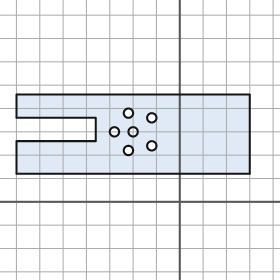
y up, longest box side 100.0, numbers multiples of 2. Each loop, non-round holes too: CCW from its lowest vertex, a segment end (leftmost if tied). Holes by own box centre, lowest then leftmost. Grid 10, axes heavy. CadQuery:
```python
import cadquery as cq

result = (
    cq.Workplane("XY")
    .moveTo(-70.0, 12.0)
    .lineTo(30.0, 12.0)
    .lineTo(30.0, 46.0)
    .lineTo(-70.0, 46.0)
    .lineTo(-70.0, 36.0)
    .lineTo(-36.0, 36.0)
    .lineTo(-36.0, 26.0)
    .lineTo(-70.0, 26.0)
    .close()
    .moveTo(-22.0, 22.0)
    .circle(2.0)
    .moveTo(-12.0, 24.0)
    .circle(2.0)
    .moveTo(-28.0, 30.0)
    .circle(2.0)
    .moveTo(-20.0, 30.0)
    .circle(2.0)
    .moveTo(-12.0, 36.0)
    .circle(2.0)
    .moveTo(-22.0, 38.0)
    .circle(2.0)
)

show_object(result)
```